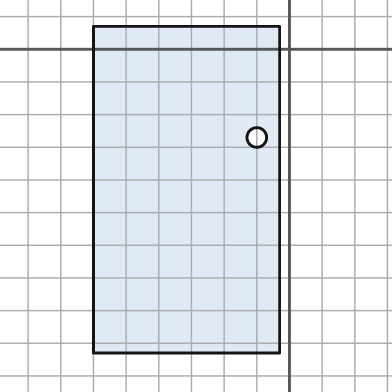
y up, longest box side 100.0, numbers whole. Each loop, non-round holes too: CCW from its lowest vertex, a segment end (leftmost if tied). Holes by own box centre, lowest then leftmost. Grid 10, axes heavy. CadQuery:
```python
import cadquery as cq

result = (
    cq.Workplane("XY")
    .moveTo(-60.0, -93.0)
    .lineTo(-3.0, -93.0)
    .lineTo(-3.0, 7.0)
    .lineTo(-60.0, 7.0)
    .close()
    .moveTo(-10.0, -27.0)
    .circle(3.0)
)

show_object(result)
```